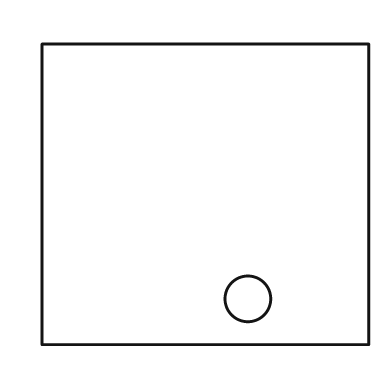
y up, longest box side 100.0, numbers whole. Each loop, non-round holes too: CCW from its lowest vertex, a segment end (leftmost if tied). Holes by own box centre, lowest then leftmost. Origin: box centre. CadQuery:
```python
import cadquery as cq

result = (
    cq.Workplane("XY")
    .moveTo(-50.0, -46.0)
    .lineTo(50.0, -46.0)
    .lineTo(50.0, 46.0)
    .lineTo(-50.0, 46.0)
    .close()
    .moveTo(13.0, -32.0)
    .circle(7.0)
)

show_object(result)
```